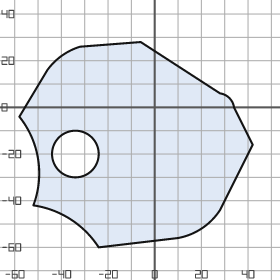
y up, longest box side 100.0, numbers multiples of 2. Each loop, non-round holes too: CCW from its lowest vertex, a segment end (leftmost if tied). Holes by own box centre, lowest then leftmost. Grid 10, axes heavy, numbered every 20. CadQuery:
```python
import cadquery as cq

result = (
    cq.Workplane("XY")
    .moveTo(-24.0, -60.0)
    .lineTo(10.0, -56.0)
    .threePointArc((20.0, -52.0), (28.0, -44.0))
    .lineTo(42.0, -16.0)
    .lineTo(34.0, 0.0)
    .threePointArc((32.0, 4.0), (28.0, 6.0))
    .lineTo(-6.0, 28.0)
    .lineTo(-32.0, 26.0)
    .threePointArc((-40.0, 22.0), (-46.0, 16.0))
    .lineTo(-58.0, -4.0)
    .threePointArc((-50.0, -22.0), (-52.0, -42.0))
    .threePointArc((-36.0, -48.0), (-24.0, -60.0))
    .close()
    .moveTo(-34.0, -20.0)
    .circle(10.0)
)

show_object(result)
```